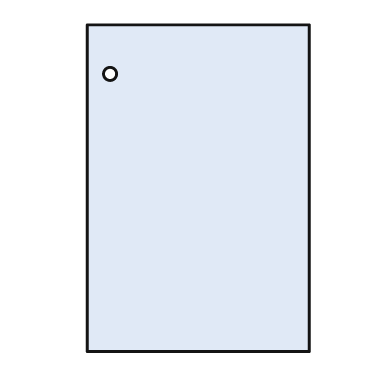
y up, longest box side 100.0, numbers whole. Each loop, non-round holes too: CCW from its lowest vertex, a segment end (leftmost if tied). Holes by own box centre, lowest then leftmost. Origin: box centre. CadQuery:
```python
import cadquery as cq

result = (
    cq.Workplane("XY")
    .moveTo(-34.0, -50.0)
    .lineTo(34.0, -50.0)
    .lineTo(34.0, 50.0)
    .lineTo(-34.0, 50.0)
    .close()
    .moveTo(-27.0, 35.0)
    .circle(2.0)
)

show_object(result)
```